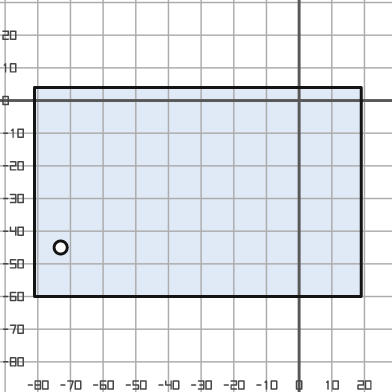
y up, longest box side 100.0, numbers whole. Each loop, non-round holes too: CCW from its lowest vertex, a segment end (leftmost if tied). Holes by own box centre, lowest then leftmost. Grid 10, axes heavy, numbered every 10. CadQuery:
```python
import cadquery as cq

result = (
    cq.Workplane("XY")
    .moveTo(-81.0, -60.0)
    .lineTo(19.0, -60.0)
    .lineTo(19.0, 4.0)
    .lineTo(-81.0, 4.0)
    .close()
    .moveTo(-73.0, -45.0)
    .circle(2.0)
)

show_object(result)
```